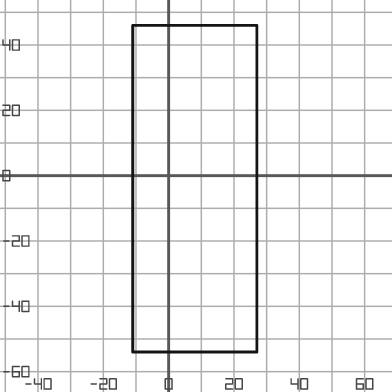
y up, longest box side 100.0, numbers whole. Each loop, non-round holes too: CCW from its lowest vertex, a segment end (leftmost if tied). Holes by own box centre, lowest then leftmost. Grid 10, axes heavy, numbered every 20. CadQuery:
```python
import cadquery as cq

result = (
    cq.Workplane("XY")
    .moveTo(-11.0, -54.0)
    .lineTo(27.0, -54.0)
    .lineTo(27.0, 46.0)
    .lineTo(-11.0, 46.0)
    .close()
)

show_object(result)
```